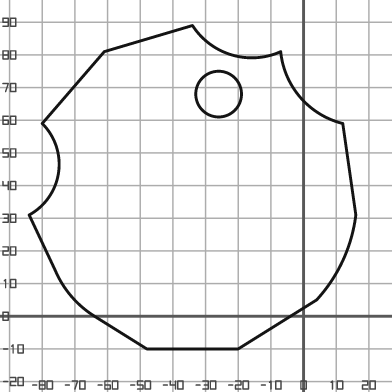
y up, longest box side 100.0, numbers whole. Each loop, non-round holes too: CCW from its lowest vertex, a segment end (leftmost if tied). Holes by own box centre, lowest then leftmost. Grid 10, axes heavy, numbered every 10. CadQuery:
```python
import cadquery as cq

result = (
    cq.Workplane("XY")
    .moveTo(-48.0, -10.0)
    .lineTo(-20.0, -10.0)
    .lineTo(4.0, 5.0)
    .threePointArc((12.0, 17.0), (16.0, 31.0))
    .lineTo(12.0, 59.0)
    .threePointArc((-1.0, 67.0), (-7.0, 81.0))
    .threePointArc((-22.0, 80.0), (-34.0, 89.0))
    .lineTo(-61.0, 81.0)
    .lineTo(-80.0, 59.0)
    .threePointArc((-75.0, 44.0), (-84.0, 31.0))
    .lineTo(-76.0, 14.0)
    .threePointArc((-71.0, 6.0), (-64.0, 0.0))
    .close()
    .moveTo(-26.0, 68.0)
    .circle(7.0)
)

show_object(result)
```